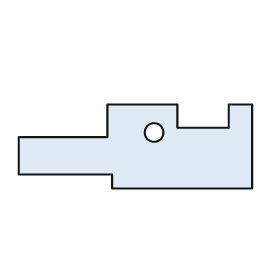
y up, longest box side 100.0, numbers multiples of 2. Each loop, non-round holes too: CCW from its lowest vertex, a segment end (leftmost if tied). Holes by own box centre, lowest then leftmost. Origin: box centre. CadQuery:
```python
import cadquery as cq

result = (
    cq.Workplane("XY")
    .moveTo(-10.0, -18.0)
    .lineTo(50.0, -18.0)
    .lineTo(50.0, 18.0)
    .lineTo(40.0, 18.0)
    .lineTo(40.0, 8.0)
    .lineTo(18.0, 8.0)
    .lineTo(18.0, 18.0)
    .lineTo(-12.0, 18.0)
    .lineTo(-12.0, 4.0)
    .lineTo(-50.0, 4.0)
    .lineTo(-50.0, -12.0)
    .lineTo(-10.0, -12.0)
    .close()
    .moveTo(8.0, 6.0)
    .circle(4.0)
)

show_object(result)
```